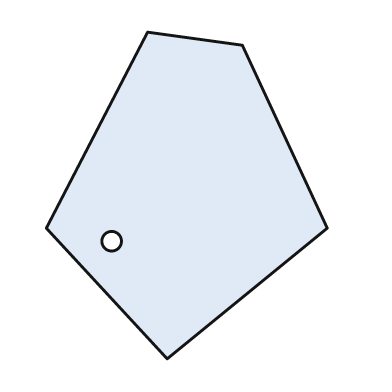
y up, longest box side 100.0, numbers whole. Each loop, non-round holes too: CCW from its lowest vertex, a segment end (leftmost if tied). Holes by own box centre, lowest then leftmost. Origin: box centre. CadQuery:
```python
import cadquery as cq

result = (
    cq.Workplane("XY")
    .moveTo(-6.0, -50.0)
    .lineTo(43.0, -10.0)
    .lineTo(17.0, 46.0)
    .lineTo(-12.0, 50.0)
    .lineTo(-43.0, -10.0)
    .close()
    .moveTo(-23.0, -14.0)
    .circle(3.0)
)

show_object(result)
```